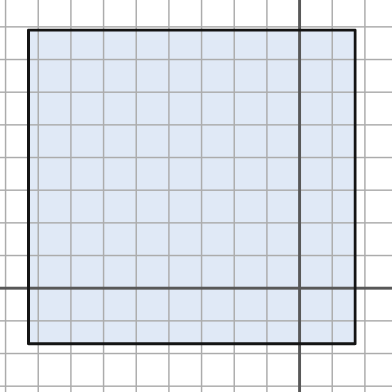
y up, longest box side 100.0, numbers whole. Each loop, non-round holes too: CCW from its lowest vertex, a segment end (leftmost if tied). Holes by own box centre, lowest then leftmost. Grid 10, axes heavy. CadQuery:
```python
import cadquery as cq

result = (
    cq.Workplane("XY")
    .moveTo(-83.0, -17.0)
    .lineTo(17.0, -17.0)
    .lineTo(17.0, 79.0)
    .lineTo(-83.0, 79.0)
    .close()
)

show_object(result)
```